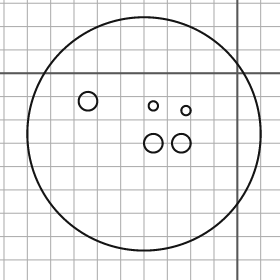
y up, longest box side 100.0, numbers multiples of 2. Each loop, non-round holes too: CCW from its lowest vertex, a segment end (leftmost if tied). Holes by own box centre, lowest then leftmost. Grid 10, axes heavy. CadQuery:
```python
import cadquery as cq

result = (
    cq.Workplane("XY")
    .moveTo(-40.0, -26.0)
    .circle(50.0)
    .moveTo(-36.0, -30.0)
    .circle(4.0)
    .moveTo(-24.0, -30.0)
    .circle(4.0)
    .moveTo(-22.0, -16.0)
    .circle(2.0)
    .moveTo(-36.0, -14.0)
    .circle(2.0)
    .moveTo(-64.0, -12.0)
    .circle(4.0)
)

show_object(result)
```